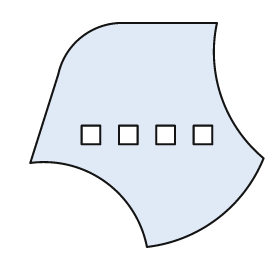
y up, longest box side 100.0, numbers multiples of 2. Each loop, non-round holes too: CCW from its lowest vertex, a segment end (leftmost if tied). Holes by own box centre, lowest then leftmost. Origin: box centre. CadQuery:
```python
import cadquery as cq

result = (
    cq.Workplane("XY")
    .moveTo(0.0, -48.0)
    .threePointArc((30.0, -36.0), (50.0, -10.0))
    .threePointArc((32.0, 16.0), (30.0, 48.0))
    .lineTo(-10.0, 48.0)
    .threePointArc((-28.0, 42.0), (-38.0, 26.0))
    .lineTo(-50.0, -12.0)
    .threePointArc((-18.0, -20.0), (0.0, -48.0))
    .close()
    .moveTo(-28.0, -4.0)
    .lineTo(-20.0, -4.0)
    .lineTo(-20.0, 4.0)
    .lineTo(-28.0, 4.0)
    .close()
    .moveTo(-12.0, -4.0)
    .lineTo(-4.0, -4.0)
    .lineTo(-4.0, 4.0)
    .lineTo(-12.0, 4.0)
    .close()
    .moveTo(4.0, -4.0)
    .lineTo(12.0, -4.0)
    .lineTo(12.0, 4.0)
    .lineTo(4.0, 4.0)
    .close()
    .moveTo(20.0, -4.0)
    .lineTo(28.0, -4.0)
    .lineTo(28.0, 4.0)
    .lineTo(20.0, 4.0)
    .close()
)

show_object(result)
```